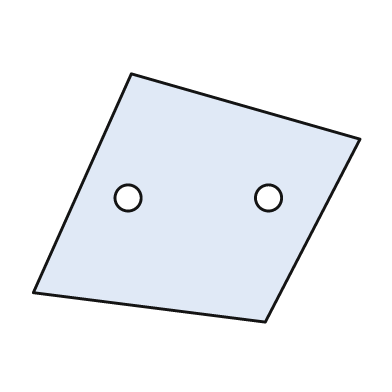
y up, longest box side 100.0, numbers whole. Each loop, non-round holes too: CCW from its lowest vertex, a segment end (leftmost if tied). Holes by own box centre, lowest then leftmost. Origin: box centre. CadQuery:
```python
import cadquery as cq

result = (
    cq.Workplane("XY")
    .moveTo(21.0, -38.0)
    .lineTo(50.0, 18.0)
    .lineTo(-20.0, 38.0)
    .lineTo(-50.0, -29.0)
    .close()
    .moveTo(-21.0, 0.0)
    .circle(4.0)
    .moveTo(22.0, 0.0)
    .circle(4.0)
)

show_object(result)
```